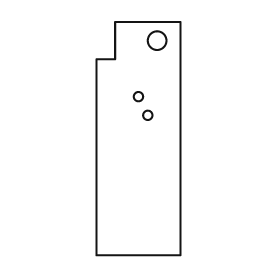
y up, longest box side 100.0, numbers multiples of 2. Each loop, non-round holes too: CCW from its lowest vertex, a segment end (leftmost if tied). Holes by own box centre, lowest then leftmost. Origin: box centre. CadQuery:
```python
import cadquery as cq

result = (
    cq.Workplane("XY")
    .moveTo(-18.0, -50.0)
    .lineTo(18.0, -50.0)
    .lineTo(18.0, 50.0)
    .lineTo(-10.0, 50.0)
    .lineTo(-10.0, 34.0)
    .lineTo(-18.0, 34.0)
    .close()
    .moveTo(4.0, 10.0)
    .circle(2.0)
    .moveTo(0.0, 18.0)
    .circle(2.0)
    .moveTo(8.0, 42.0)
    .circle(4.0)
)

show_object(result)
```